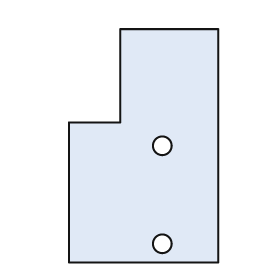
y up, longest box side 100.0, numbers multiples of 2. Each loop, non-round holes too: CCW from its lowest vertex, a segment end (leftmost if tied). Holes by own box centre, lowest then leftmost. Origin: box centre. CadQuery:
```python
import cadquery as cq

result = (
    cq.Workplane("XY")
    .moveTo(-32.0, -50.0)
    .lineTo(32.0, -50.0)
    .lineTo(32.0, 50.0)
    .lineTo(-10.0, 50.0)
    .lineTo(-10.0, 10.0)
    .lineTo(-32.0, 10.0)
    .close()
    .moveTo(8.0, -42.0)
    .circle(4.0)
    .moveTo(8.0, 0.0)
    .circle(4.0)
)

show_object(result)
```